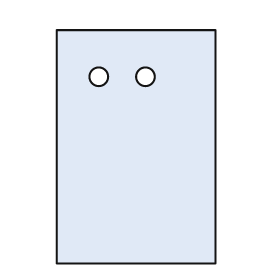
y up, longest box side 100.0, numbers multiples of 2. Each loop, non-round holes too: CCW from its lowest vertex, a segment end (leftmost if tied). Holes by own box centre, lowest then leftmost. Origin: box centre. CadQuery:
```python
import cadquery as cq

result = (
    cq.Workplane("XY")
    .moveTo(-34.0, -50.0)
    .lineTo(34.0, -50.0)
    .lineTo(34.0, 50.0)
    .lineTo(-34.0, 50.0)
    .close()
    .moveTo(-16.0, 30.0)
    .circle(4.0)
    .moveTo(4.0, 30.0)
    .circle(4.0)
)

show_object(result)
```